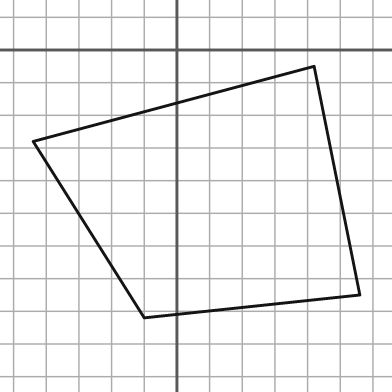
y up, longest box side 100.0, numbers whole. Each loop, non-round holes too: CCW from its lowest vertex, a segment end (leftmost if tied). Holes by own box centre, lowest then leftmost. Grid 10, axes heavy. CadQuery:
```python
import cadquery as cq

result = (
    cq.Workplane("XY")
    .moveTo(-10.0, -82.0)
    .lineTo(56.0, -75.0)
    .lineTo(42.0, -5.0)
    .lineTo(-44.0, -28.0)
    .close()
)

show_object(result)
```